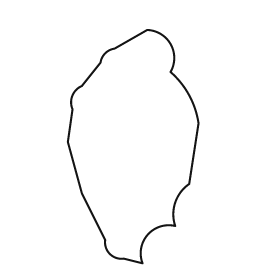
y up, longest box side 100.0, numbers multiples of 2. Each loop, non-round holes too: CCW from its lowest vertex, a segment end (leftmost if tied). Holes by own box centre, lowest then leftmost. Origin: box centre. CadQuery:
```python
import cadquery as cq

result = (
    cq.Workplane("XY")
    .moveTo(4.0, -50.0)
    .threePointArc((6.0, -38.0), (18.0, -34.0))
    .threePointArc((18.0, -24.0), (24.0, -16.0))
    .lineTo(28.0, 10.0)
    .threePointArc((24.0, 22.0), (16.0, 32.0))
    .threePointArc((16.0, 44.0), (6.0, 50.0))
    .lineTo(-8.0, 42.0)
    .threePointArc((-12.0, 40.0), (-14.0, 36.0))
    .lineTo(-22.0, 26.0)
    .threePointArc((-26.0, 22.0), (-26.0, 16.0))
    .lineTo(-28.0, 2.0)
    .lineTo(-22.0, -20.0)
    .lineTo(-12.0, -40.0)
    .threePointArc((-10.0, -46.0), (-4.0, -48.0))
    .close()
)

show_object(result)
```